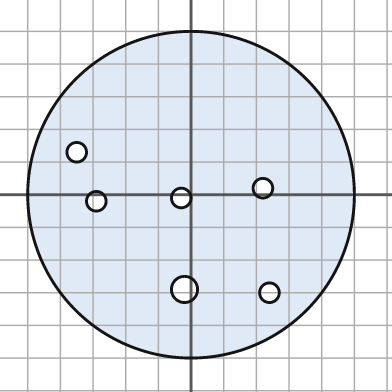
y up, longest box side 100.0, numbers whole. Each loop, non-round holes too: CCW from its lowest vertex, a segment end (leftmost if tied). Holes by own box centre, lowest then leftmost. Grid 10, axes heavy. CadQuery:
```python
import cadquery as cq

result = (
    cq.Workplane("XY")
    .moveTo(0.0, 0.0)
    .circle(50.0)
    .moveTo(24.0, -30.0)
    .circle(3.0)
    .moveTo(-2.0, -29.0)
    .circle(4.0)
    .moveTo(-29.0, -2.0)
    .circle(3.0)
    .moveTo(-3.0, -1.0)
    .circle(3.0)
    .moveTo(22.0, 2.0)
    .circle(3.0)
    .moveTo(-35.0, 13.0)
    .circle(3.0)
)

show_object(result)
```